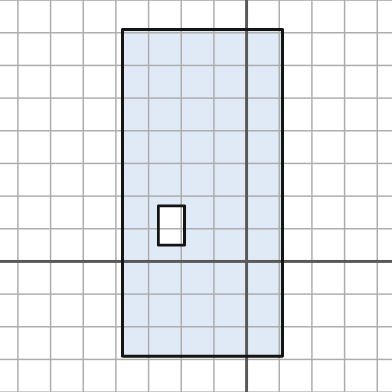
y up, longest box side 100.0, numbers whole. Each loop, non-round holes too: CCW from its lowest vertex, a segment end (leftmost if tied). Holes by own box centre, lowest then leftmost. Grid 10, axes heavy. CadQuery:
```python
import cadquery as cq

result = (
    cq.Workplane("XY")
    .moveTo(-38.0, -29.0)
    .lineTo(11.0, -29.0)
    .lineTo(11.0, 71.0)
    .lineTo(-38.0, 71.0)
    .close()
    .moveTo(-27.0, 5.0)
    .lineTo(-19.0, 5.0)
    .lineTo(-19.0, 17.0)
    .lineTo(-27.0, 17.0)
    .close()
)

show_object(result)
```